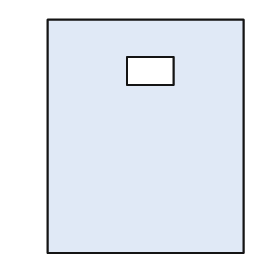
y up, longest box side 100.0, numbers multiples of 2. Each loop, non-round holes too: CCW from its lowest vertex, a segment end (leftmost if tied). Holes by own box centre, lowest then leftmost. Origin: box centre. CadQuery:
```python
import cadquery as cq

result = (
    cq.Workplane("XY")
    .moveTo(-42.0, -50.0)
    .lineTo(42.0, -50.0)
    .lineTo(42.0, 50.0)
    .lineTo(-42.0, 50.0)
    .close()
    .moveTo(-8.0, 22.0)
    .lineTo(12.0, 22.0)
    .lineTo(12.0, 34.0)
    .lineTo(-8.0, 34.0)
    .close()
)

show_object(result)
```